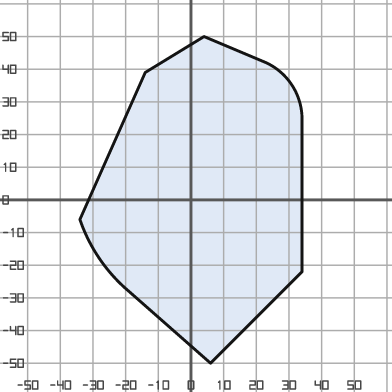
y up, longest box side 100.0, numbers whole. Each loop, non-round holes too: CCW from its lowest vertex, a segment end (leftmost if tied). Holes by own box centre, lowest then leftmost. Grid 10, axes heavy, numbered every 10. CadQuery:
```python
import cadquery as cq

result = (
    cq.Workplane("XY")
    .moveTo(6.0, -50.0)
    .lineTo(34.0, -22.0)
    .lineTo(34.0, 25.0)
    .threePointArc((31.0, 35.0), (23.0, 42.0))
    .lineTo(4.0, 50.0)
    .lineTo(-14.0, 39.0)
    .lineTo(-34.0, -6.0)
    .threePointArc((-28.0, -18.0), (-19.0, -28.0))
    .close()
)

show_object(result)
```